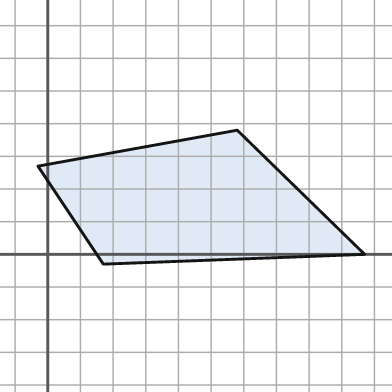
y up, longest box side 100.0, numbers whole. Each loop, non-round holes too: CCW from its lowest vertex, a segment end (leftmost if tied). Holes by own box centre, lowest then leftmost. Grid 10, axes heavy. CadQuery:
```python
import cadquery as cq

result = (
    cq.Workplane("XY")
    .moveTo(17.0, -3.0)
    .lineTo(97.0, 0.0)
    .lineTo(58.0, 38.0)
    .lineTo(-3.0, 27.0)
    .close()
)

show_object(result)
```